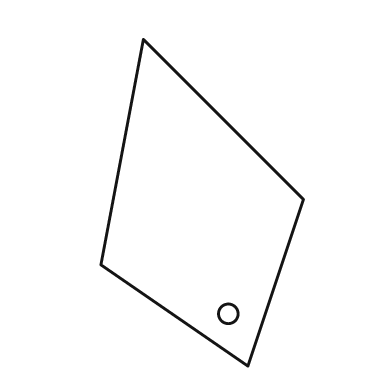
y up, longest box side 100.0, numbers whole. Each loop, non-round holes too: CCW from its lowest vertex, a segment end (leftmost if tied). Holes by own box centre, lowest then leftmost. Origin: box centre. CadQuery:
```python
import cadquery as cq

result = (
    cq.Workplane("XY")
    .moveTo(14.0, -50.0)
    .lineTo(31.0, 1.0)
    .lineTo(-18.0, 50.0)
    .lineTo(-31.0, -19.0)
    .close()
    .moveTo(8.0, -34.0)
    .circle(3.0)
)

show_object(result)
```